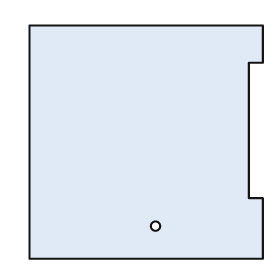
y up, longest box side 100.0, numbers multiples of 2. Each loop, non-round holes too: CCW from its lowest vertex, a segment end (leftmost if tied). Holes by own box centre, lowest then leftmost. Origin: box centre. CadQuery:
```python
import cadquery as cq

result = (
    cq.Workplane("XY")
    .moveTo(-50.0, -50.0)
    .lineTo(50.0, -50.0)
    .lineTo(50.0, -24.0)
    .lineTo(44.0, -24.0)
    .lineTo(44.0, 34.0)
    .lineTo(50.0, 34.0)
    .lineTo(50.0, 50.0)
    .lineTo(-50.0, 50.0)
    .close()
    .moveTo(4.0, -36.0)
    .circle(2.0)
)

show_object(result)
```